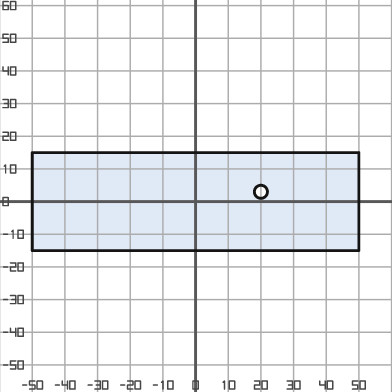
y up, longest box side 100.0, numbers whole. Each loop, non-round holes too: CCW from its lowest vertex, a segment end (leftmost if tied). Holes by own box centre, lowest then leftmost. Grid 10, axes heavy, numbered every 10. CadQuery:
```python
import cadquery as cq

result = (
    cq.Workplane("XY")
    .moveTo(-50.0, -15.0)
    .lineTo(50.0, -15.0)
    .lineTo(50.0, 15.0)
    .lineTo(-50.0, 15.0)
    .close()
    .moveTo(20.0, 3.0)
    .circle(2.0)
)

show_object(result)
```